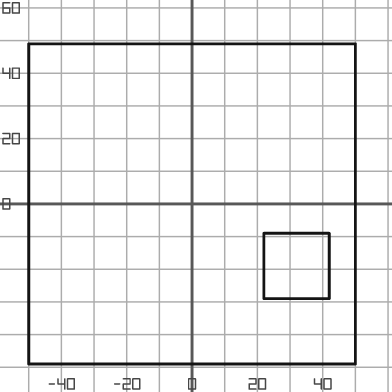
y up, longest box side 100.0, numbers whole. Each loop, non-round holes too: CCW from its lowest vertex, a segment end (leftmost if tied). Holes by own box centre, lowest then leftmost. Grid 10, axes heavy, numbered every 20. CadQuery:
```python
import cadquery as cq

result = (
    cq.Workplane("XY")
    .moveTo(-50.0, -49.0)
    .lineTo(50.0, -49.0)
    .lineTo(50.0, 49.0)
    .lineTo(-50.0, 49.0)
    .close()
    .moveTo(22.0, -29.0)
    .lineTo(42.0, -29.0)
    .lineTo(42.0, -9.0)
    .lineTo(22.0, -9.0)
    .close()
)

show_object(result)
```